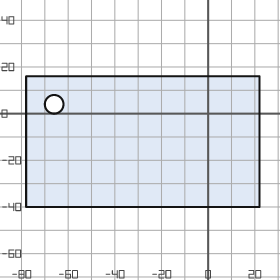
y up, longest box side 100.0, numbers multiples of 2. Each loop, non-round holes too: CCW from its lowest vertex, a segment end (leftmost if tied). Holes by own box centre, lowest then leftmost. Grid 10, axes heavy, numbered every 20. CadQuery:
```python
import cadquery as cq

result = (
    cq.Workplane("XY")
    .moveTo(-78.0, -40.0)
    .lineTo(22.0, -40.0)
    .lineTo(22.0, 16.0)
    .lineTo(-78.0, 16.0)
    .close()
    .moveTo(-66.0, 4.0)
    .circle(4.0)
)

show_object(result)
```